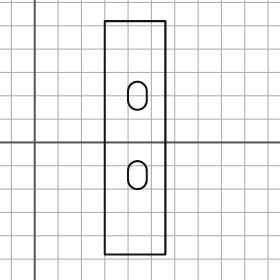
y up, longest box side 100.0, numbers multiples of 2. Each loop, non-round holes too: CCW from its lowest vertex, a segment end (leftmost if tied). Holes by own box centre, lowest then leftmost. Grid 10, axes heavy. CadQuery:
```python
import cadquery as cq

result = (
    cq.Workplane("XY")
    .moveTo(30.0, -48.0)
    .lineTo(56.0, -48.0)
    .lineTo(56.0, 52.0)
    .lineTo(30.0, 52.0)
    .close()
    .moveTo(40.0, -16.0)
    .threePointArc((44.0, -20.0), (48.0, -16.0))
    .lineTo(48.0, -12.0)
    .threePointArc((44.0, -8.0), (40.0, -12.0))
    .close()
    .moveTo(40.0, 18.0)
    .threePointArc((44.0, 14.0), (48.0, 18.0))
    .lineTo(48.0, 22.0)
    .threePointArc((44.0, 26.0), (40.0, 22.0))
    .close()
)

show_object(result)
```